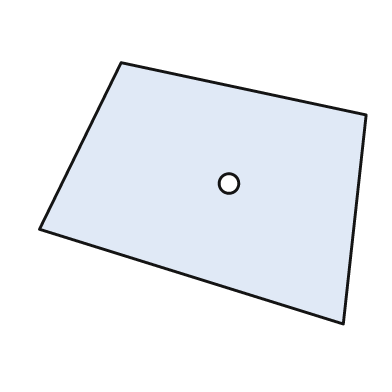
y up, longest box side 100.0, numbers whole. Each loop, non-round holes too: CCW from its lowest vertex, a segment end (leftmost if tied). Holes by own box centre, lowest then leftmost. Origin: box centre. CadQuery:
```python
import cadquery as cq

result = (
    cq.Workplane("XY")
    .moveTo(43.0, -40.0)
    .lineTo(50.0, 24.0)
    .lineTo(-25.0, 40.0)
    .lineTo(-50.0, -11.0)
    .close()
    .moveTo(8.0, 3.0)
    .circle(3.0)
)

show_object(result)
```